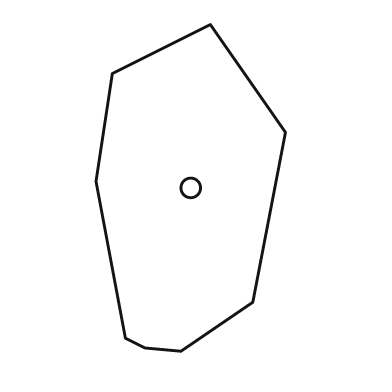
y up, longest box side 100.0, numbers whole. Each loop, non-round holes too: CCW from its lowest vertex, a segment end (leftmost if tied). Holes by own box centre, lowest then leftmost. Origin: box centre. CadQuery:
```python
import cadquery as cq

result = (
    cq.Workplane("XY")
    .moveTo(-3.0, -50.0)
    .lineTo(19.0, -35.0)
    .lineTo(29.0, 17.0)
    .lineTo(6.0, 50.0)
    .lineTo(-24.0, 35.0)
    .lineTo(-29.0, 2.0)
    .lineTo(-20.0, -46.0)
    .lineTo(-14.0, -49.0)
    .close()
    .moveTo(0.0, 0.0)
    .circle(3.0)
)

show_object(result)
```